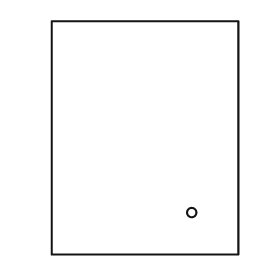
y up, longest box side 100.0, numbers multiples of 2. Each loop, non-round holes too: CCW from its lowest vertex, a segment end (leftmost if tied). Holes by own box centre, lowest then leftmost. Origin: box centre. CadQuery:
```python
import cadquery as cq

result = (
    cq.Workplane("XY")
    .moveTo(-40.0, -50.0)
    .lineTo(40.0, -50.0)
    .lineTo(40.0, 50.0)
    .lineTo(-40.0, 50.0)
    .close()
    .moveTo(20.0, -32.0)
    .circle(2.0)
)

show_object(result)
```